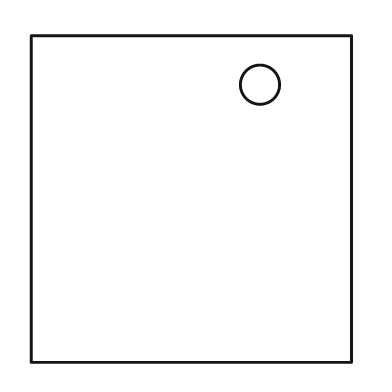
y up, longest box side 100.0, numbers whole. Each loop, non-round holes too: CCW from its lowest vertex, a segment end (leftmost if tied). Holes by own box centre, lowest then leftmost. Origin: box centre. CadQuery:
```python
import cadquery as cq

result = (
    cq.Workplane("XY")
    .moveTo(-49.0, -50.0)
    .lineTo(49.0, -50.0)
    .lineTo(49.0, 50.0)
    .lineTo(-49.0, 50.0)
    .close()
    .moveTo(21.0, 35.0)
    .circle(6.0)
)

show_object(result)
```